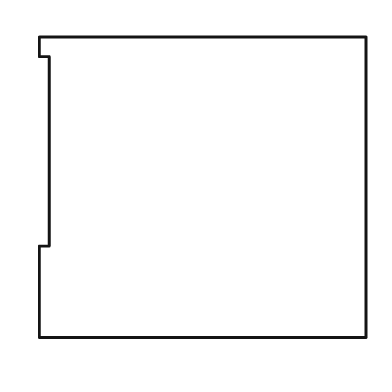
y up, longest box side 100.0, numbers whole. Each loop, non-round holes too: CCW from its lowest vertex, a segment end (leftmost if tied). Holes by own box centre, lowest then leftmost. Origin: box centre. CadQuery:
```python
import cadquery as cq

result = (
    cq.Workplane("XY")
    .moveTo(-50.0, -46.0)
    .lineTo(50.0, -46.0)
    .lineTo(50.0, 46.0)
    .lineTo(-50.0, 46.0)
    .lineTo(-50.0, 40.0)
    .lineTo(-47.0, 40.0)
    .lineTo(-47.0, -18.0)
    .lineTo(-50.0, -18.0)
    .close()
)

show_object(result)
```